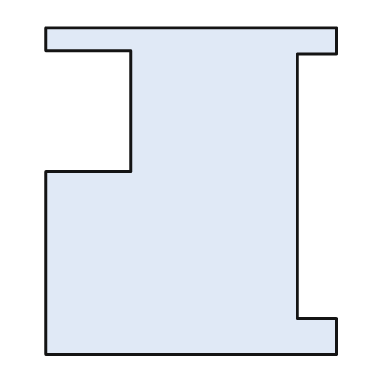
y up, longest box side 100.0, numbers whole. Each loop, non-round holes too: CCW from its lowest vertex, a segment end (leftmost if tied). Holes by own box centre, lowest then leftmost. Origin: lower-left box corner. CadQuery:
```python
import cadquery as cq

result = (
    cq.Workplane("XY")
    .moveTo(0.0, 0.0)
    .lineTo(89.0, 0.0)
    .lineTo(89.0, 11.0)
    .lineTo(77.0, 11.0)
    .lineTo(77.0, 92.0)
    .lineTo(89.0, 92.0)
    .lineTo(89.0, 100.0)
    .lineTo(0.0, 100.0)
    .lineTo(0.0, 93.0)
    .lineTo(26.0, 93.0)
    .lineTo(26.0, 56.0)
    .lineTo(0.0, 56.0)
    .close()
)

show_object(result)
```